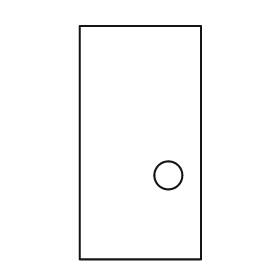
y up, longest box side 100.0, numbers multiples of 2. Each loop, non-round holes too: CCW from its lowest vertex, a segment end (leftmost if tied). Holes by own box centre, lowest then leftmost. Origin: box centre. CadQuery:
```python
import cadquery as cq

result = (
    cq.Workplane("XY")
    .moveTo(-26.0, -50.0)
    .lineTo(26.0, -50.0)
    .lineTo(26.0, 50.0)
    .lineTo(-26.0, 50.0)
    .close()
    .moveTo(12.0, -14.0)
    .circle(6.0)
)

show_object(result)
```